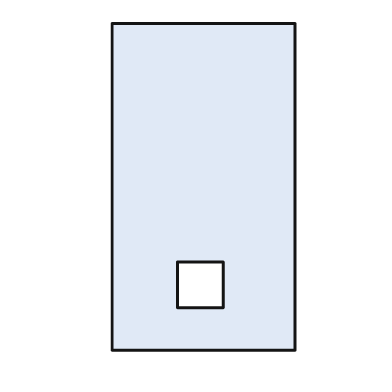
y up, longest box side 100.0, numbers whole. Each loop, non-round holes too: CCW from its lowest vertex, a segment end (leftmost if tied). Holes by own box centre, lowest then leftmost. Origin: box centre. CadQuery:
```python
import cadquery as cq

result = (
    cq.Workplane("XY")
    .moveTo(-28.0, -50.0)
    .lineTo(28.0, -50.0)
    .lineTo(28.0, 50.0)
    .lineTo(-28.0, 50.0)
    .close()
    .moveTo(-8.0, -37.0)
    .lineTo(6.0, -37.0)
    .lineTo(6.0, -23.0)
    .lineTo(-8.0, -23.0)
    .close()
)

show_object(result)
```